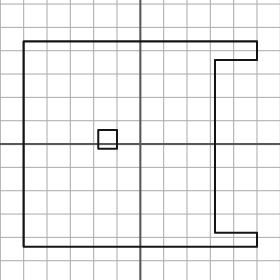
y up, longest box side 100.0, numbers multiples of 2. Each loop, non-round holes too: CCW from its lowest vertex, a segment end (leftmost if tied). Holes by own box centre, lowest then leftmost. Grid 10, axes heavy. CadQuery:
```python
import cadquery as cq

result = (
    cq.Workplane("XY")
    .moveTo(-50.0, -44.0)
    .lineTo(50.0, -44.0)
    .lineTo(50.0, -38.0)
    .lineTo(32.0, -38.0)
    .lineTo(32.0, 36.0)
    .lineTo(50.0, 36.0)
    .lineTo(50.0, 44.0)
    .lineTo(-50.0, 44.0)
    .close()
    .moveTo(-18.0, -2.0)
    .lineTo(-10.0, -2.0)
    .lineTo(-10.0, 6.0)
    .lineTo(-18.0, 6.0)
    .close()
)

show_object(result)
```